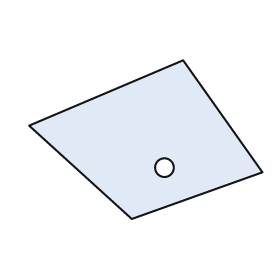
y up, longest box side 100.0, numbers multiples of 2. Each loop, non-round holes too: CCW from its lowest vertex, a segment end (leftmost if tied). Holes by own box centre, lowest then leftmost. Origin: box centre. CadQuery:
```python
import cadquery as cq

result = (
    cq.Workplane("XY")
    .moveTo(-6.0, -34.0)
    .lineTo(50.0, -14.0)
    .lineTo(16.0, 34.0)
    .lineTo(-50.0, 6.0)
    .close()
    .moveTo(8.0, -12.0)
    .circle(4.0)
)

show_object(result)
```